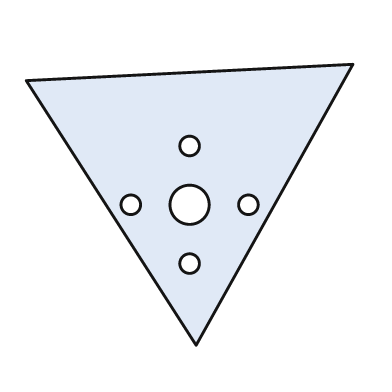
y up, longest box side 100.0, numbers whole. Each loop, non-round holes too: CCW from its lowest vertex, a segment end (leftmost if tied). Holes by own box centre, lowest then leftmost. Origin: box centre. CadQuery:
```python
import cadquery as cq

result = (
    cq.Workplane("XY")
    .moveTo(2.0, -43.0)
    .lineTo(50.0, 43.0)
    .lineTo(-50.0, 38.0)
    .close()
    .moveTo(0.0, -18.0)
    .circle(3.0)
    .moveTo(-18.0, 0.0)
    .circle(3.0)
    .moveTo(0.0, 0.0)
    .circle(6.0)
    .moveTo(18.0, 0.0)
    .circle(3.0)
    .moveTo(0.0, 18.0)
    .circle(3.0)
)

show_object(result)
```